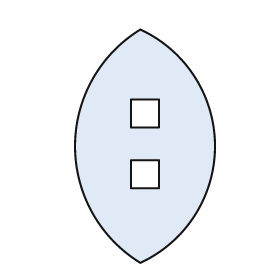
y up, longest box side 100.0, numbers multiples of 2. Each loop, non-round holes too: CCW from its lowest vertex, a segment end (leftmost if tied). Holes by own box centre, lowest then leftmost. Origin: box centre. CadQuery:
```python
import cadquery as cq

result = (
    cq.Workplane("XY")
    .moveTo(-2.0, -50.0)
    .threePointArc((30.0, 0.0), (-2.0, 50.0))
    .threePointArc((-30.0, 0.0), (-2.0, -50.0))
    .close()
    .moveTo(-6.0, -18.0)
    .lineTo(6.0, -18.0)
    .lineTo(6.0, -6.0)
    .lineTo(-6.0, -6.0)
    .close()
    .moveTo(-6.0, 8.0)
    .lineTo(6.0, 8.0)
    .lineTo(6.0, 20.0)
    .lineTo(-6.0, 20.0)
    .close()
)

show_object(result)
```